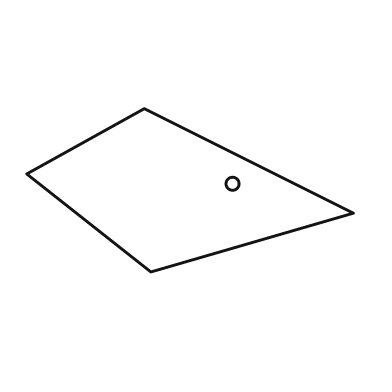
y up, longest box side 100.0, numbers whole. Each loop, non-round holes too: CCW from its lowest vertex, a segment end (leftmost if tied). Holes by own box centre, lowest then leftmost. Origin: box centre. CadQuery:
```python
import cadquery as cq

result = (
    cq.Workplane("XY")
    .moveTo(-12.0, -25.0)
    .lineTo(50.0, -7.0)
    .lineTo(-14.0, 25.0)
    .lineTo(-50.0, 5.0)
    .close()
    .moveTo(13.0, 2.0)
    .circle(2.0)
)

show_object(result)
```